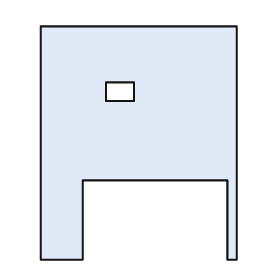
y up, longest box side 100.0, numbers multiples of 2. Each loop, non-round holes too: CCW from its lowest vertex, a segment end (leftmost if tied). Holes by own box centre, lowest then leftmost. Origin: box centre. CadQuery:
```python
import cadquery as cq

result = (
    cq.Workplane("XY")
    .moveTo(-42.0, -50.0)
    .lineTo(-24.0, -50.0)
    .lineTo(-24.0, -16.0)
    .lineTo(38.0, -16.0)
    .lineTo(38.0, -50.0)
    .lineTo(42.0, -50.0)
    .lineTo(42.0, 50.0)
    .lineTo(-42.0, 50.0)
    .close()
    .moveTo(-14.0, 18.0)
    .lineTo(-2.0, 18.0)
    .lineTo(-2.0, 26.0)
    .lineTo(-14.0, 26.0)
    .close()
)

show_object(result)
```